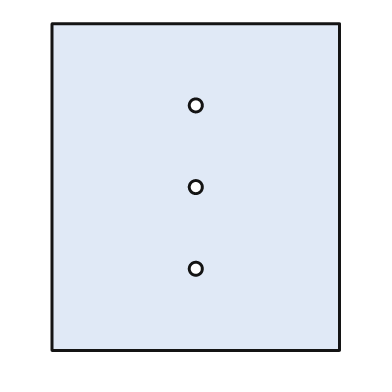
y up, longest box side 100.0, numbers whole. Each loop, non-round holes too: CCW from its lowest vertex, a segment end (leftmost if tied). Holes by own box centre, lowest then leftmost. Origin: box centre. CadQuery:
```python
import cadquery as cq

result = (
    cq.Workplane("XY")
    .moveTo(-44.0, -50.0)
    .lineTo(44.0, -50.0)
    .lineTo(44.0, 50.0)
    .lineTo(-44.0, 50.0)
    .close()
    .moveTo(0.0, -25.0)
    .circle(2.0)
    .moveTo(0.0, 0.0)
    .circle(2.0)
    .moveTo(0.0, 25.0)
    .circle(2.0)
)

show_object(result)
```